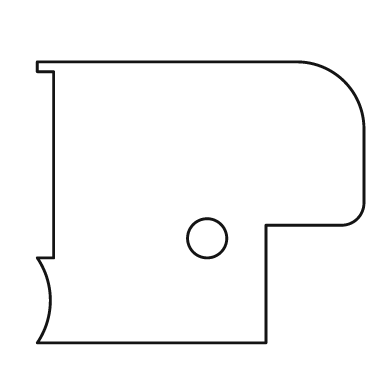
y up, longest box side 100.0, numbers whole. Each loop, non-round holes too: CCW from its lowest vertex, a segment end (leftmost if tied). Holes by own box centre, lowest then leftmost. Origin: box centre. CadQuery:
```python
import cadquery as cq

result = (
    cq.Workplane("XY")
    .moveTo(-50.0, -43.0)
    .lineTo(20.0, -43.0)
    .lineTo(20.0, -7.0)
    .lineTo(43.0, -7.0)
    .threePointArc((48.0, -5.0), (50.0, 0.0))
    .lineTo(50.0, 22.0)
    .threePointArc((44.0, 37.0), (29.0, 43.0))
    .lineTo(-50.0, 43.0)
    .lineTo(-50.0, 40.0)
    .lineTo(-45.0, 40.0)
    .lineTo(-45.0, -17.0)
    .lineTo(-50.0, -17.0)
    .threePointArc((-46.0, -30.0), (-50.0, -43.0))
    .close()
    .moveTo(2.0, -11.0)
    .circle(6.0)
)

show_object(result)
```